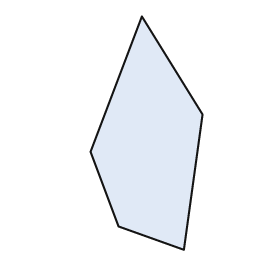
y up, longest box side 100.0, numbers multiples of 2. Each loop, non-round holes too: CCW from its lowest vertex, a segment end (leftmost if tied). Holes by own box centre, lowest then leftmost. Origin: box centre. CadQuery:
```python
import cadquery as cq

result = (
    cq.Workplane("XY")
    .moveTo(16.0, -50.0)
    .lineTo(24.0, 8.0)
    .lineTo(-2.0, 50.0)
    .lineTo(-24.0, -8.0)
    .lineTo(-12.0, -40.0)
    .close()
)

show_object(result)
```